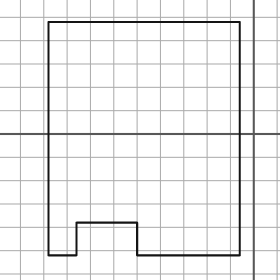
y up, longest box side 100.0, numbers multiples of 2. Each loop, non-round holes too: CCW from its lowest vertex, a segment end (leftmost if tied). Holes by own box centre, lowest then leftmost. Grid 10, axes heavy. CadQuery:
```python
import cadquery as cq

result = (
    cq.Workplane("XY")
    .moveTo(-88.0, -52.0)
    .lineTo(-76.0, -52.0)
    .lineTo(-76.0, -38.0)
    .lineTo(-50.0, -38.0)
    .lineTo(-50.0, -52.0)
    .lineTo(-6.0, -52.0)
    .lineTo(-6.0, 48.0)
    .lineTo(-88.0, 48.0)
    .close()
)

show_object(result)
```